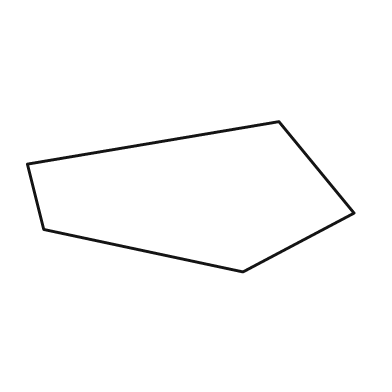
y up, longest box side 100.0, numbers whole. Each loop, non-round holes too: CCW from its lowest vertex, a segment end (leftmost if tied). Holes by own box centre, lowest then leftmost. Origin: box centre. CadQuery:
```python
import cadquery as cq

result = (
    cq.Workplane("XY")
    .moveTo(16.0, -23.0)
    .lineTo(50.0, -5.0)
    .lineTo(27.0, 23.0)
    .lineTo(-50.0, 10.0)
    .lineTo(-45.0, -10.0)
    .close()
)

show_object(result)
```